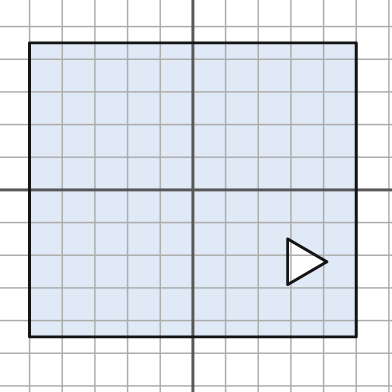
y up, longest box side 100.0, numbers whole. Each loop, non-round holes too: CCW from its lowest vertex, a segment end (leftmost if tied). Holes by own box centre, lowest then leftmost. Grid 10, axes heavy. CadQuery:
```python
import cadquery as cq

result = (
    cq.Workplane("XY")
    .moveTo(-50.0, -45.0)
    .lineTo(50.0, -45.0)
    .lineTo(50.0, 45.0)
    .lineTo(-50.0, 45.0)
    .close()
    .moveTo(29.0, -29.0)
    .lineTo(41.0, -22.0)
    .lineTo(29.0, -15.0)
    .close()
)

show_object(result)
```